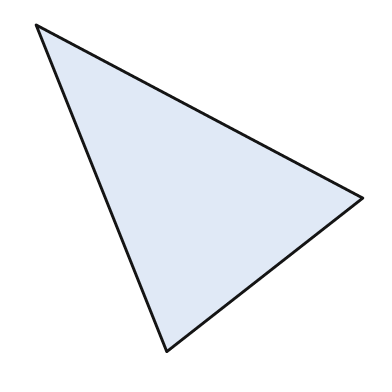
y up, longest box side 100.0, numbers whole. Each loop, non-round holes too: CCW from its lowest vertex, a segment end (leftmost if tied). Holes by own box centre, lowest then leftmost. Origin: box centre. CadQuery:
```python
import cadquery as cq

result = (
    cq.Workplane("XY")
    .moveTo(-10.0, -50.0)
    .lineTo(50.0, -3.0)
    .lineTo(-50.0, 50.0)
    .close()
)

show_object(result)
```